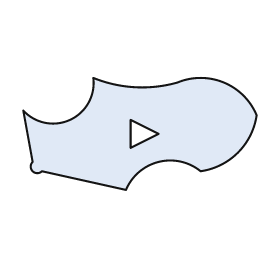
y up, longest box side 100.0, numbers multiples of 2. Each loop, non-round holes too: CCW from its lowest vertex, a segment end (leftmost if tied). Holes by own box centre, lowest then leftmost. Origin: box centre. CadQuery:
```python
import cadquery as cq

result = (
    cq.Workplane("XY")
    .moveTo(-6.0, -24.0)
    .threePointArc((8.0, -12.0), (26.0, -16.0))
    .threePointArc((42.0, -8.0), (50.0, 8.0))
    .threePointArc((36.0, 22.0), (16.0, 22.0))
    .threePointArc((-2.0, 20.0), (-20.0, 24.0))
    .threePointArc((-30.0, 6.0), (-50.0, 10.0))
    .lineTo(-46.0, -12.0)
    .threePointArc((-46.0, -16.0), (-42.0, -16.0))
    .close()
    .moveTo(-4.0, -6.0)
    .lineTo(8.0, 0.0)
    .lineTo(-4.0, 6.0)
    .close()
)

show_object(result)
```